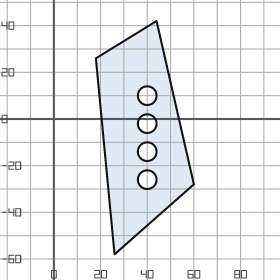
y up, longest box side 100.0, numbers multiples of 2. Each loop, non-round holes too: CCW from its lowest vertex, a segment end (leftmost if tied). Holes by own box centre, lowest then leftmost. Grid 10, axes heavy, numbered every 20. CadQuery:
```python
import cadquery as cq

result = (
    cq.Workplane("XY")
    .moveTo(26.0, -58.0)
    .lineTo(60.0, -28.0)
    .lineTo(44.0, 42.0)
    .lineTo(18.0, 26.0)
    .close()
    .moveTo(40.0, -26.0)
    .circle(4.0)
    .moveTo(40.0, -14.0)
    .circle(4.0)
    .moveTo(40.0, -2.0)
    .circle(4.0)
    .moveTo(40.0, 10.0)
    .circle(4.0)
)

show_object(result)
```